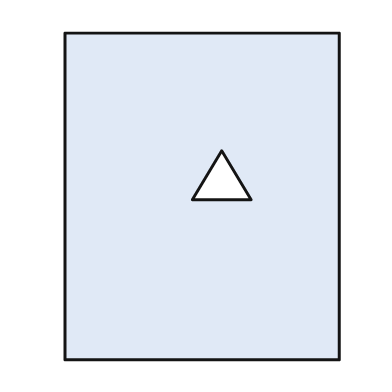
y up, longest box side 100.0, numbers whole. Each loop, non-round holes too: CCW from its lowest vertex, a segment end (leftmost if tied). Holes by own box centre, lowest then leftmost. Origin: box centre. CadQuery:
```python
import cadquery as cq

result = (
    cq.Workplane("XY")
    .moveTo(-42.0, -50.0)
    .lineTo(42.0, -50.0)
    .lineTo(42.0, 50.0)
    .lineTo(-42.0, 50.0)
    .close()
    .moveTo(-3.0, -1.0)
    .lineTo(15.0, -1.0)
    .lineTo(6.0, 14.0)
    .close()
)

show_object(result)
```